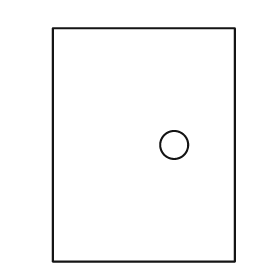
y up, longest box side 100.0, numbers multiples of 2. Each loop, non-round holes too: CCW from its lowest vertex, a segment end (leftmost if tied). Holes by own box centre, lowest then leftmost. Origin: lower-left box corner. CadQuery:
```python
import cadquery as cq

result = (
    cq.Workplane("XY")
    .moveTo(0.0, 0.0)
    .lineTo(78.0, 0.0)
    .lineTo(78.0, 100.0)
    .lineTo(0.0, 100.0)
    .close()
    .moveTo(52.0, 50.0)
    .circle(6.0)
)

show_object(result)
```